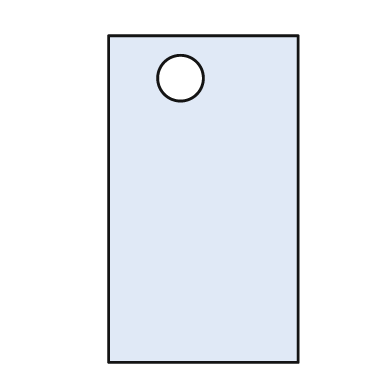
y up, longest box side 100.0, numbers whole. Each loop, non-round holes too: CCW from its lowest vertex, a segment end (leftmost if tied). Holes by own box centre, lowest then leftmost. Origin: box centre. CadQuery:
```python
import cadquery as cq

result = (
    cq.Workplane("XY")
    .moveTo(-29.0, -50.0)
    .lineTo(29.0, -50.0)
    .lineTo(29.0, 50.0)
    .lineTo(-29.0, 50.0)
    .close()
    .moveTo(-7.0, 37.0)
    .circle(7.0)
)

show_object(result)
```